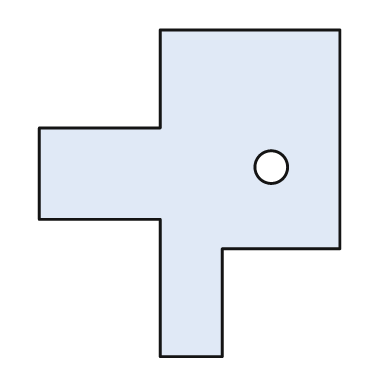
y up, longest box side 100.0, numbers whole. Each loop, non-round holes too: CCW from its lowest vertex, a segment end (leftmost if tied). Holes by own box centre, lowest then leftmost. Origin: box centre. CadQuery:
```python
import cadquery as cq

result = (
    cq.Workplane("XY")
    .moveTo(-9.0, -50.0)
    .lineTo(10.0, -50.0)
    .lineTo(10.0, -17.0)
    .lineTo(46.0, -17.0)
    .lineTo(46.0, 50.0)
    .lineTo(-9.0, 50.0)
    .lineTo(-9.0, 20.0)
    .lineTo(-46.0, 20.0)
    .lineTo(-46.0, -8.0)
    .lineTo(-9.0, -8.0)
    .close()
    .moveTo(25.0, 8.0)
    .circle(5.0)
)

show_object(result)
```